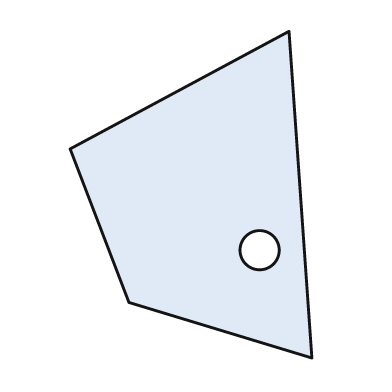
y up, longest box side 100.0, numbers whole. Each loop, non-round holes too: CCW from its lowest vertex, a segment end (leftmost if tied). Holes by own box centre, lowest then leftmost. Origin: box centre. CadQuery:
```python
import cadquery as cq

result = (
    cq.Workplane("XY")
    .moveTo(37.0, -50.0)
    .lineTo(30.0, 50.0)
    .lineTo(-37.0, 14.0)
    .lineTo(-19.0, -33.0)
    .close()
    .moveTo(21.0, -17.0)
    .circle(6.0)
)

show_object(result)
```